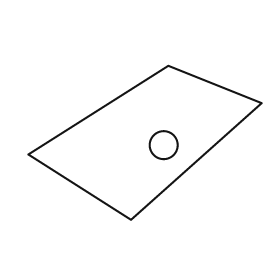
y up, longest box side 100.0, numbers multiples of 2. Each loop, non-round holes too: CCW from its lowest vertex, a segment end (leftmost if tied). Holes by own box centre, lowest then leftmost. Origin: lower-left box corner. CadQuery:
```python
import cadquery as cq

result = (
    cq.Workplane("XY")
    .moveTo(44.0, 0.0)
    .lineTo(100.0, 50.0)
    .lineTo(60.0, 66.0)
    .lineTo(0.0, 28.0)
    .close()
    .moveTo(58.0, 32.0)
    .circle(6.0)
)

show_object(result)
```